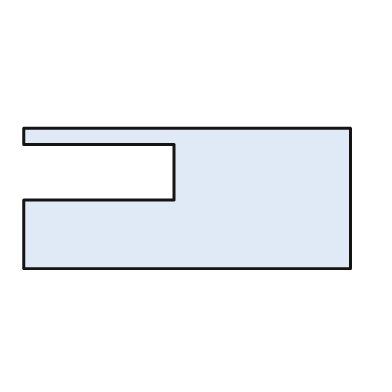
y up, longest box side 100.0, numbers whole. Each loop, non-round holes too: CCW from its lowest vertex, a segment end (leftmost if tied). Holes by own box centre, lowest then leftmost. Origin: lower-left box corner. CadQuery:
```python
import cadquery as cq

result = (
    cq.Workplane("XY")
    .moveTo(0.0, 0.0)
    .lineTo(100.0, 0.0)
    .lineTo(100.0, 43.0)
    .lineTo(0.0, 43.0)
    .lineTo(0.0, 38.0)
    .lineTo(46.0, 38.0)
    .lineTo(46.0, 21.0)
    .lineTo(0.0, 21.0)
    .close()
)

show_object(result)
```